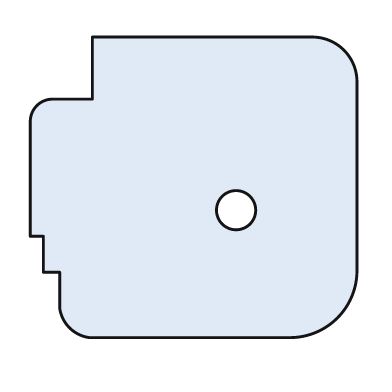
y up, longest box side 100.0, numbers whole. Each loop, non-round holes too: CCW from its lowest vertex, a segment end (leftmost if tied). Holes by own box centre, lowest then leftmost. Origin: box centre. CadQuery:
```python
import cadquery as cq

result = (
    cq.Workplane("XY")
    .moveTo(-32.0, -46.0)
    .lineTo(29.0, -46.0)
    .threePointArc((44.0, -40.0), (50.0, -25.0))
    .lineTo(50.0, 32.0)
    .threePointArc((46.0, 42.0), (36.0, 46.0))
    .lineTo(-31.0, 46.0)
    .lineTo(-31.0, 27.0)
    .lineTo(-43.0, 27.0)
    .threePointArc((-48.0, 25.0), (-50.0, 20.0))
    .lineTo(-50.0, -15.0)
    .lineTo(-46.0, -15.0)
    .lineTo(-46.0, -26.0)
    .lineTo(-41.0, -26.0)
    .lineTo(-41.0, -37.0)
    .threePointArc((-38.0, -43.0), (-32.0, -46.0))
    .close()
    .moveTo(13.0, -7.0)
    .circle(6.0)
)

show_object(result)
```